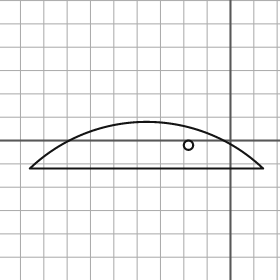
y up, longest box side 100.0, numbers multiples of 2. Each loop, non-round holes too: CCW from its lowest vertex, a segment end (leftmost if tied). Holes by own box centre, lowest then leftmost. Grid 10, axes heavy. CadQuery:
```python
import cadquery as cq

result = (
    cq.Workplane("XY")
    .moveTo(-86.0, -12.0)
    .lineTo(14.0, -12.0)
    .threePointArc((-36.0, 8.0), (-86.0, -12.0))
    .close()
    .moveTo(-18.0, -2.0)
    .circle(2.0)
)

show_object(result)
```